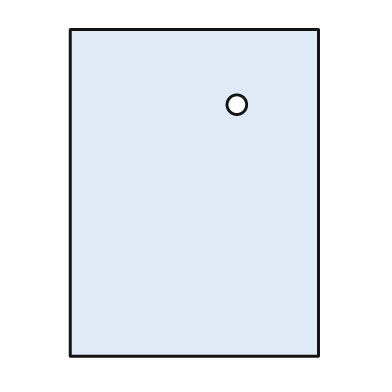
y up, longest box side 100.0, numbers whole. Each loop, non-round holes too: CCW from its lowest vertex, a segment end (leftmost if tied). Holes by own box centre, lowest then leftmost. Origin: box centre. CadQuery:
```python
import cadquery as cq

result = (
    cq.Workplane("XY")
    .moveTo(-38.0, -50.0)
    .lineTo(38.0, -50.0)
    .lineTo(38.0, 50.0)
    .lineTo(-38.0, 50.0)
    .close()
    .moveTo(13.0, 27.0)
    .circle(3.0)
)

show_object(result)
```